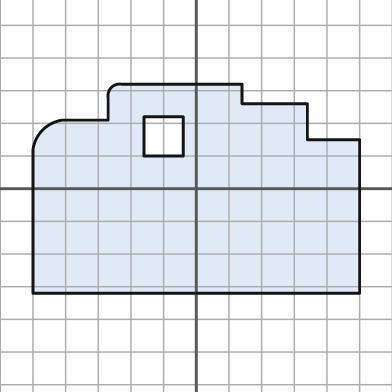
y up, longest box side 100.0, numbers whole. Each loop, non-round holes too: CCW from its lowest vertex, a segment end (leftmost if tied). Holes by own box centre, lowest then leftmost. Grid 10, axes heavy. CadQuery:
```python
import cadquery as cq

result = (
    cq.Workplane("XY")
    .moveTo(-50.0, -32.0)
    .lineTo(50.0, -32.0)
    .lineTo(50.0, 15.0)
    .lineTo(34.0, 15.0)
    .lineTo(34.0, 26.0)
    .lineTo(14.0, 26.0)
    .lineTo(14.0, 32.0)
    .lineTo(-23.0, 32.0)
    .threePointArc((-26.0, 31.0), (-27.0, 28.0))
    .lineTo(-27.0, 21.0)
    .lineTo(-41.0, 21.0)
    .threePointArc((-47.0, 18.0), (-50.0, 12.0))
    .close()
    .moveTo(-16.0, 10.0)
    .lineTo(-4.0, 10.0)
    .lineTo(-4.0, 22.0)
    .lineTo(-16.0, 22.0)
    .close()
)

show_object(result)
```